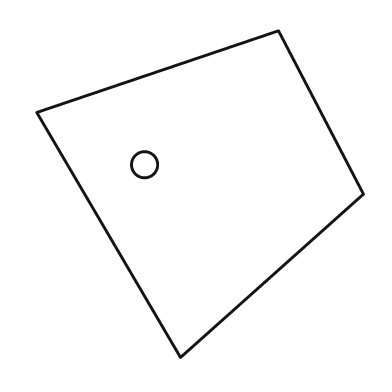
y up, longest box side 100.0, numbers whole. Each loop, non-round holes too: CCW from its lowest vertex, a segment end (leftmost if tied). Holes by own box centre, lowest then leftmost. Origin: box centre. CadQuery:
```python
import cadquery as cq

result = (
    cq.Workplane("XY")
    .moveTo(-6.0, -50.0)
    .lineTo(50.0, 0.0)
    .lineTo(24.0, 50.0)
    .lineTo(-50.0, 25.0)
    .close()
    .moveTo(-17.0, 9.0)
    .circle(4.0)
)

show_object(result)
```